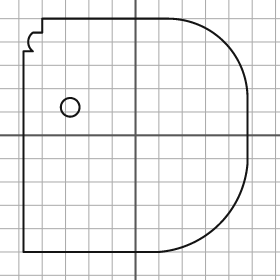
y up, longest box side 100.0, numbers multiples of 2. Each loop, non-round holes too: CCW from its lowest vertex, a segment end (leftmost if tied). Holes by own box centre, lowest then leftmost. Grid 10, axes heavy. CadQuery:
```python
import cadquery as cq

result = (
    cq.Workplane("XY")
    .moveTo(-48.0, -50.0)
    .lineTo(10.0, -50.0)
    .threePointArc((36.0, -38.0), (48.0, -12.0))
    .lineTo(48.0, 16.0)
    .threePointArc((38.0, 40.0), (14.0, 50.0))
    .lineTo(-40.0, 50.0)
    .lineTo(-40.0, 44.0)
    .lineTo(-44.0, 44.0)
    .threePointArc((-46.0, 40.0), (-44.0, 36.0))
    .lineTo(-48.0, 36.0)
    .close()
    .moveTo(-28.0, 12.0)
    .circle(4.0)
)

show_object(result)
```